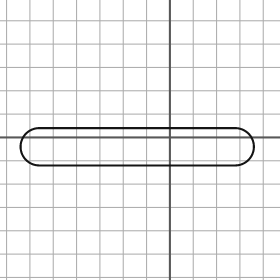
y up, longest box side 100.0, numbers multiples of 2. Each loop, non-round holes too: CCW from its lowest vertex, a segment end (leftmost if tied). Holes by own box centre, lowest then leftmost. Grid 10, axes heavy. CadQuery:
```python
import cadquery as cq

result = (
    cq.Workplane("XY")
    .moveTo(-56.0, -12.0)
    .lineTo(28.0, -12.0)
    .threePointArc((36.0, -4.0), (28.0, 4.0))
    .lineTo(-56.0, 4.0)
    .threePointArc((-64.0, -4.0), (-56.0, -12.0))
    .close()
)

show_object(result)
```